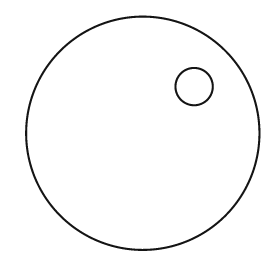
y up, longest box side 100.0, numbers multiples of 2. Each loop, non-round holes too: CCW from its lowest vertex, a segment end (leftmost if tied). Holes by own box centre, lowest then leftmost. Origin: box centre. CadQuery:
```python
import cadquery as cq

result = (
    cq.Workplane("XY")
    .moveTo(0.0, 0.0)
    .circle(50.0)
    .moveTo(22.0, 20.0)
    .circle(8.0)
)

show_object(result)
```